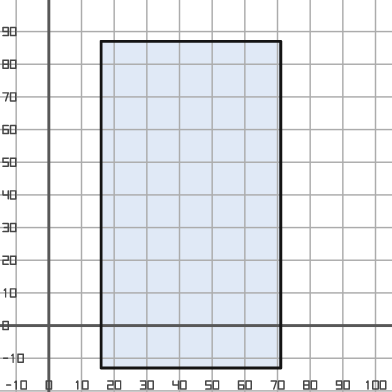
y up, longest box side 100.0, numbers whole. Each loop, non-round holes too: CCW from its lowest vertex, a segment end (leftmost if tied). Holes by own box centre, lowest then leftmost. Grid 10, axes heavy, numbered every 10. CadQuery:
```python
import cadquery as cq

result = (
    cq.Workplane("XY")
    .moveTo(16.0, -13.0)
    .lineTo(71.0, -13.0)
    .lineTo(71.0, 87.0)
    .lineTo(16.0, 87.0)
    .close()
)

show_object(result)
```